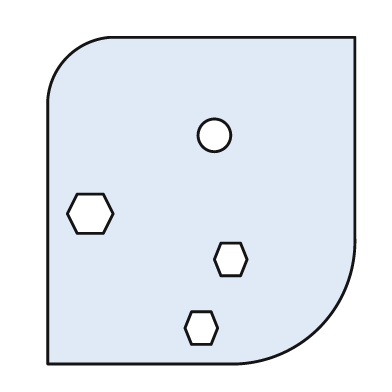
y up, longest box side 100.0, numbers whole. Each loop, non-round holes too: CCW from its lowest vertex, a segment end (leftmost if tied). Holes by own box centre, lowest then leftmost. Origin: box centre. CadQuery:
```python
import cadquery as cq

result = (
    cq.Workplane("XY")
    .moveTo(-47.0, -50.0)
    .lineTo(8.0, -50.0)
    .threePointArc((36.0, -39.0), (47.0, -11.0))
    .lineTo(47.0, 50.0)
    .lineTo(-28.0, 50.0)
    .threePointArc((-41.0, 44.0), (-47.0, 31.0))
    .close()
    .moveTo(-3.0, -44.0)
    .lineTo(3.0, -44.0)
    .lineTo(5.0, -39.0)
    .lineTo(3.0, -34.0)
    .lineTo(-3.0, -34.0)
    .lineTo(-5.0, -39.0)
    .close()
    .moveTo(6.0, -23.0)
    .lineTo(12.0, -23.0)
    .lineTo(14.0, -18.0)
    .lineTo(12.0, -13.0)
    .lineTo(6.0, -13.0)
    .lineTo(4.0, -18.0)
    .close()
    .moveTo(-38.0, -10.0)
    .lineTo(-30.0, -10.0)
    .lineTo(-27.0, -4.0)
    .lineTo(-30.0, 2.0)
    .lineTo(-38.0, 2.0)
    .lineTo(-41.0, -4.0)
    .close()
    .moveTo(4.0, 20.0)
    .circle(5.0)
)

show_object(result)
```